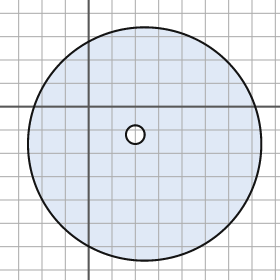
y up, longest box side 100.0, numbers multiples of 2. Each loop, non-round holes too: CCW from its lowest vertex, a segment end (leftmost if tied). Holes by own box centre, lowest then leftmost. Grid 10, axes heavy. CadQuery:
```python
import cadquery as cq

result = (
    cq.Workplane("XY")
    .moveTo(24.0, -16.0)
    .circle(50.0)
    .moveTo(20.0, -12.0)
    .circle(4.0)
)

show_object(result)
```